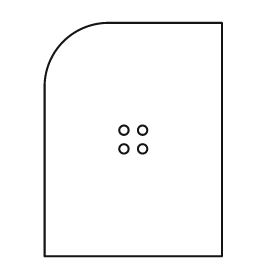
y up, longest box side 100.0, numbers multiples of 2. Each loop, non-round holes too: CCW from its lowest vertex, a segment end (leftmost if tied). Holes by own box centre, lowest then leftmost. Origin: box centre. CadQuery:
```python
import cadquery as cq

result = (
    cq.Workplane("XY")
    .moveTo(-38.0, -50.0)
    .lineTo(38.0, -50.0)
    .lineTo(38.0, 50.0)
    .lineTo(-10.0, 50.0)
    .threePointArc((-30.0, 42.0), (-38.0, 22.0))
    .close()
    .moveTo(-4.0, -4.0)
    .circle(2.0)
    .moveTo(4.0, -4.0)
    .circle(2.0)
    .moveTo(-4.0, 4.0)
    .circle(2.0)
    .moveTo(4.0, 4.0)
    .circle(2.0)
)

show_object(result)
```